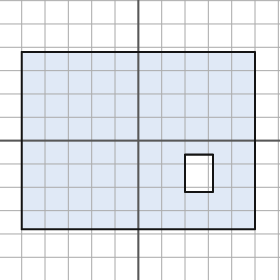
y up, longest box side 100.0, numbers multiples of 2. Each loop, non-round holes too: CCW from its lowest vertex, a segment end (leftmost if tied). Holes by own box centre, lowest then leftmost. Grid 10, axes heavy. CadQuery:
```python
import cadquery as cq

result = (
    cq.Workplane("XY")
    .moveTo(-50.0, -38.0)
    .lineTo(50.0, -38.0)
    .lineTo(50.0, 38.0)
    .lineTo(-50.0, 38.0)
    .close()
    .moveTo(20.0, -22.0)
    .lineTo(32.0, -22.0)
    .lineTo(32.0, -6.0)
    .lineTo(20.0, -6.0)
    .close()
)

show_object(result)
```